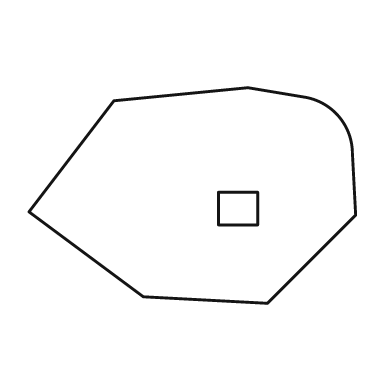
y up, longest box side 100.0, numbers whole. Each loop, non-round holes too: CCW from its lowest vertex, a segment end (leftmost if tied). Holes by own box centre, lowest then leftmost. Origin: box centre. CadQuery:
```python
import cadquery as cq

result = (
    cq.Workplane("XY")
    .moveTo(23.0, -33.0)
    .lineTo(50.0, -6.0)
    .lineTo(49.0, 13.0)
    .threePointArc((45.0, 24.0), (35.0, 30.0))
    .lineTo(17.0, 33.0)
    .lineTo(-24.0, 29.0)
    .lineTo(-50.0, -5.0)
    .lineTo(-15.0, -31.0)
    .close()
    .moveTo(8.0, -9.0)
    .lineTo(20.0, -9.0)
    .lineTo(20.0, 1.0)
    .lineTo(8.0, 1.0)
    .close()
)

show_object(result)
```